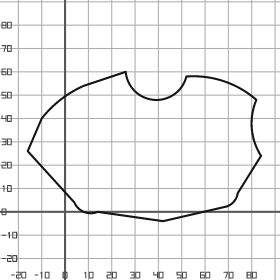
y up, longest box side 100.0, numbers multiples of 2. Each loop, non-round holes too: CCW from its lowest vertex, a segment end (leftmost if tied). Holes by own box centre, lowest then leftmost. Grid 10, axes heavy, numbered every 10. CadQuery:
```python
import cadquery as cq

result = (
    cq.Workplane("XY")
    .moveTo(42.0, -4.0)
    .lineTo(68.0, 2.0)
    .threePointArc((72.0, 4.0), (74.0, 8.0))
    .lineTo(84.0, 24.0)
    .threePointArc((80.0, 36.0), (82.0, 48.0))
    .threePointArc((68.0, 56.0), (52.0, 58.0))
    .threePointArc((38.0, 48.0), (26.0, 60.0))
    .lineTo(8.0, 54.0)
    .threePointArc((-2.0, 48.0), (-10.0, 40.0))
    .lineTo(-16.0, 26.0)
    .lineTo(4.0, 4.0)
    .threePointArc((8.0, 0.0), (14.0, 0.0))
    .close()
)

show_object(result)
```